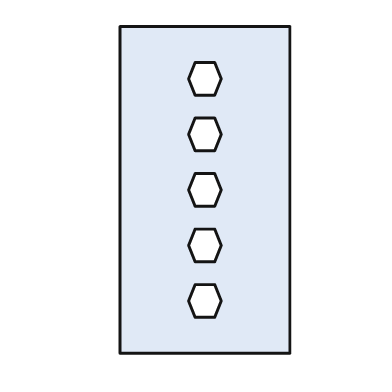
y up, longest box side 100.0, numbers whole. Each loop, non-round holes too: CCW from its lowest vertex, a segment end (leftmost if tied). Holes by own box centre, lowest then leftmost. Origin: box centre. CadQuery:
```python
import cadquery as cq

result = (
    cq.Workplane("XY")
    .moveTo(-26.0, -50.0)
    .lineTo(26.0, -50.0)
    .lineTo(26.0, 50.0)
    .lineTo(-26.0, 50.0)
    .close()
    .moveTo(-3.0, -39.0)
    .lineTo(3.0, -39.0)
    .lineTo(5.0, -34.0)
    .lineTo(3.0, -29.0)
    .lineTo(-3.0, -29.0)
    .lineTo(-5.0, -34.0)
    .close()
    .moveTo(-3.0, -22.0)
    .lineTo(3.0, -22.0)
    .lineTo(5.0, -17.0)
    .lineTo(3.0, -12.0)
    .lineTo(-3.0, -12.0)
    .lineTo(-5.0, -17.0)
    .close()
    .moveTo(-3.0, -5.0)
    .lineTo(3.0, -5.0)
    .lineTo(5.0, 0.0)
    .lineTo(3.0, 5.0)
    .lineTo(-3.0, 5.0)
    .lineTo(-5.0, 0.0)
    .close()
    .moveTo(-3.0, 12.0)
    .lineTo(3.0, 12.0)
    .lineTo(5.0, 17.0)
    .lineTo(3.0, 22.0)
    .lineTo(-3.0, 22.0)
    .lineTo(-5.0, 17.0)
    .close()
    .moveTo(-3.0, 29.0)
    .lineTo(3.0, 29.0)
    .lineTo(5.0, 34.0)
    .lineTo(3.0, 39.0)
    .lineTo(-3.0, 39.0)
    .lineTo(-5.0, 34.0)
    .close()
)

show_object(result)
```